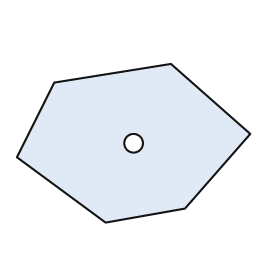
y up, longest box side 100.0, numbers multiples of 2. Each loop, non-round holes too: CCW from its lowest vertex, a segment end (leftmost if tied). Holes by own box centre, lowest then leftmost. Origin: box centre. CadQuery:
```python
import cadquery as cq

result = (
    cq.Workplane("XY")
    .moveTo(-12.0, -34.0)
    .lineTo(22.0, -28.0)
    .lineTo(50.0, 4.0)
    .lineTo(16.0, 34.0)
    .lineTo(-34.0, 26.0)
    .lineTo(-50.0, -6.0)
    .close()
    .moveTo(0.0, 0.0)
    .circle(4.0)
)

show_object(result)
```